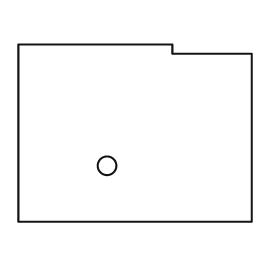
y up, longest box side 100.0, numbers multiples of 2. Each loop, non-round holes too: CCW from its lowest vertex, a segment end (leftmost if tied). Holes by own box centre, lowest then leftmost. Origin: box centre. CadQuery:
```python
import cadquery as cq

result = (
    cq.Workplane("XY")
    .moveTo(-50.0, -38.0)
    .lineTo(50.0, -38.0)
    .lineTo(50.0, 34.0)
    .lineTo(16.0, 34.0)
    .lineTo(16.0, 38.0)
    .lineTo(-50.0, 38.0)
    .close()
    .moveTo(-12.0, -14.0)
    .circle(4.0)
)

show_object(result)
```